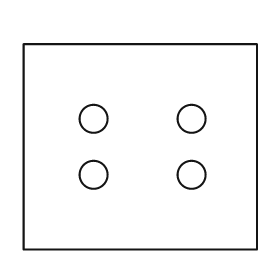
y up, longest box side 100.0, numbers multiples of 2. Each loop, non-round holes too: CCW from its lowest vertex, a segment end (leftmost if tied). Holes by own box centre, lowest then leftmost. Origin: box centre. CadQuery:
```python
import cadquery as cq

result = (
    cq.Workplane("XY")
    .moveTo(-50.0, -44.0)
    .lineTo(50.0, -44.0)
    .lineTo(50.0, 44.0)
    .lineTo(-50.0, 44.0)
    .close()
    .moveTo(-20.0, -12.0)
    .circle(6.0)
    .moveTo(22.0, -12.0)
    .circle(6.0)
    .moveTo(-20.0, 12.0)
    .circle(6.0)
    .moveTo(22.0, 12.0)
    .circle(6.0)
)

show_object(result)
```